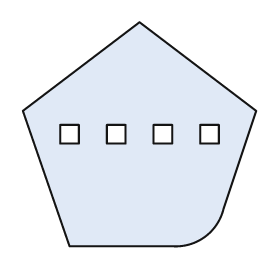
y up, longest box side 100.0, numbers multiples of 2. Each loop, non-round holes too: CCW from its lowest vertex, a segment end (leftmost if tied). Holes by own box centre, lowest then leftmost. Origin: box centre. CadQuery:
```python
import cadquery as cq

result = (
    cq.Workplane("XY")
    .moveTo(-30.0, -48.0)
    .lineTo(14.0, -48.0)
    .threePointArc((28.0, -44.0), (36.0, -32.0))
    .lineTo(50.0, 10.0)
    .lineTo(0.0, 48.0)
    .lineTo(-50.0, 10.0)
    .close()
    .moveTo(-34.0, -4.0)
    .lineTo(-26.0, -4.0)
    .lineTo(-26.0, 4.0)
    .lineTo(-34.0, 4.0)
    .close()
    .moveTo(-14.0, -4.0)
    .lineTo(-6.0, -4.0)
    .lineTo(-6.0, 4.0)
    .lineTo(-14.0, 4.0)
    .close()
    .moveTo(6.0, -4.0)
    .lineTo(14.0, -4.0)
    .lineTo(14.0, 4.0)
    .lineTo(6.0, 4.0)
    .close()
    .moveTo(26.0, -4.0)
    .lineTo(34.0, -4.0)
    .lineTo(34.0, 4.0)
    .lineTo(26.0, 4.0)
    .close()
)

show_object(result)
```